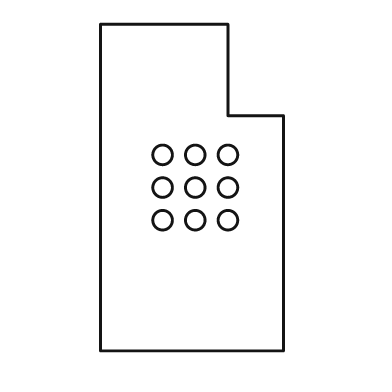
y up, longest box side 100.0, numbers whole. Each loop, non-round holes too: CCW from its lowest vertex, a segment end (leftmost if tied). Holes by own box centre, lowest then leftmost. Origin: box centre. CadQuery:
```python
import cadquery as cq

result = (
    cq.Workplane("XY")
    .moveTo(-28.0, -50.0)
    .lineTo(28.0, -50.0)
    .lineTo(28.0, 22.0)
    .lineTo(11.0, 22.0)
    .lineTo(11.0, 50.0)
    .lineTo(-28.0, 50.0)
    .close()
    .moveTo(-9.0, -10.0)
    .circle(3.0)
    .moveTo(1.0, -10.0)
    .circle(3.0)
    .moveTo(11.0, -10.0)
    .circle(3.0)
    .moveTo(-9.0, 0.0)
    .circle(3.0)
    .moveTo(1.0, 0.0)
    .circle(3.0)
    .moveTo(11.0, 0.0)
    .circle(3.0)
    .moveTo(-9.0, 10.0)
    .circle(3.0)
    .moveTo(1.0, 10.0)
    .circle(3.0)
    .moveTo(11.0, 10.0)
    .circle(3.0)
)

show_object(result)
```